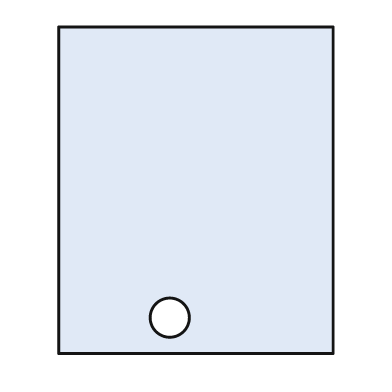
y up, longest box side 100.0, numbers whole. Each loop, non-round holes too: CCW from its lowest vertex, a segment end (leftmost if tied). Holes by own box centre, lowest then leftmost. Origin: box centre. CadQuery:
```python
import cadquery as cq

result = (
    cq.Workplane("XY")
    .moveTo(-42.0, -50.0)
    .lineTo(42.0, -50.0)
    .lineTo(42.0, 50.0)
    .lineTo(-42.0, 50.0)
    .close()
    .moveTo(-8.0, -39.0)
    .circle(6.0)
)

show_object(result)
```